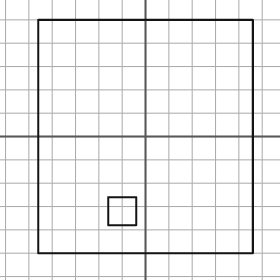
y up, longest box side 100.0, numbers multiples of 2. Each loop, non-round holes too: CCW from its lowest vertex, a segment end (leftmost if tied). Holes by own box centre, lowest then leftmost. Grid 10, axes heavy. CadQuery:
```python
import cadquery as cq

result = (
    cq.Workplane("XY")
    .moveTo(-46.0, -50.0)
    .lineTo(46.0, -50.0)
    .lineTo(46.0, 50.0)
    .lineTo(-46.0, 50.0)
    .close()
    .moveTo(-16.0, -38.0)
    .lineTo(-4.0, -38.0)
    .lineTo(-4.0, -26.0)
    .lineTo(-16.0, -26.0)
    .close()
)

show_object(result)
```